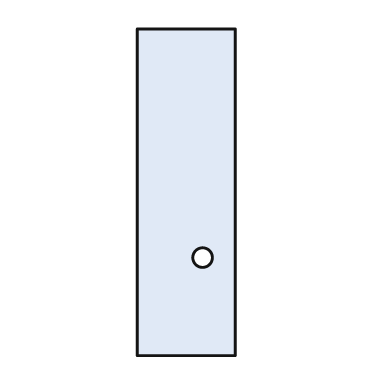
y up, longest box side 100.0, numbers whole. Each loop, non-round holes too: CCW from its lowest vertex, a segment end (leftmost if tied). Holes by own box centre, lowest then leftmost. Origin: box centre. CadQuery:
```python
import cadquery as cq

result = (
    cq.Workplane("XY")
    .moveTo(-15.0, -50.0)
    .lineTo(15.0, -50.0)
    .lineTo(15.0, 50.0)
    .lineTo(-15.0, 50.0)
    .close()
    .moveTo(5.0, -20.0)
    .circle(3.0)
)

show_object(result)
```